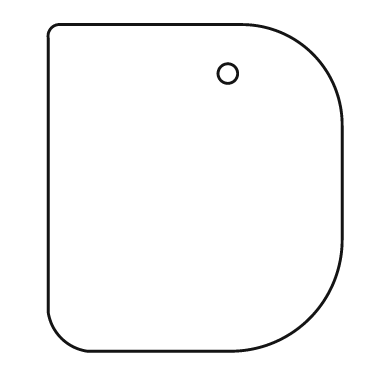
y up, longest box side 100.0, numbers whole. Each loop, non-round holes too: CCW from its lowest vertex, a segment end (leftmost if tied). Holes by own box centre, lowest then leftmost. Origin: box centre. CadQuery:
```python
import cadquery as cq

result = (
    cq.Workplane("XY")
    .moveTo(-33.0, -50.0)
    .lineTo(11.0, -50.0)
    .threePointArc((35.0, -40.0), (45.0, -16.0))
    .lineTo(45.0, 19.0)
    .threePointArc((36.0, 41.0), (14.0, 50.0))
    .lineTo(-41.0, 50.0)
    .threePointArc((-44.0, 49.0), (-45.0, 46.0))
    .lineTo(-45.0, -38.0)
    .threePointArc((-41.0, -46.0), (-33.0, -50.0))
    .close()
    .moveTo(10.0, 35.0)
    .circle(3.0)
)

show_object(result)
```